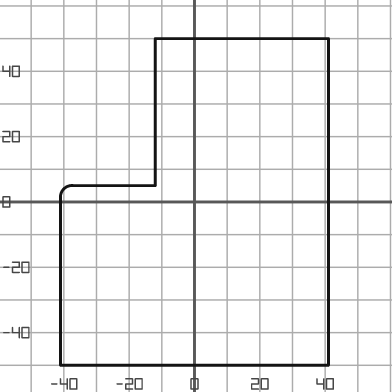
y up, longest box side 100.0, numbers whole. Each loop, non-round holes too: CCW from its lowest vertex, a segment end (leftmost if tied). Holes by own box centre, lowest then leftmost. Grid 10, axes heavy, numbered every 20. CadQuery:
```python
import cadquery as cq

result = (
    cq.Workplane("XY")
    .moveTo(-41.0, -50.0)
    .lineTo(41.0, -50.0)
    .lineTo(41.0, 50.0)
    .lineTo(-12.0, 50.0)
    .lineTo(-12.0, 5.0)
    .lineTo(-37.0, 5.0)
    .threePointArc((-40.0, 4.0), (-41.0, 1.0))
    .close()
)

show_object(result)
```